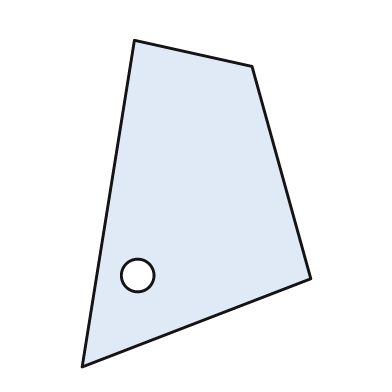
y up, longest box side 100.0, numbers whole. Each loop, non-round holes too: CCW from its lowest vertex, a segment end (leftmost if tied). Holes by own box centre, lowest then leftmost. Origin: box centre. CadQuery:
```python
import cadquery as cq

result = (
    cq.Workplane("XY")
    .moveTo(-35.0, -50.0)
    .lineTo(35.0, -23.0)
    .lineTo(17.0, 42.0)
    .lineTo(-19.0, 50.0)
    .close()
    .moveTo(-18.0, -22.0)
    .circle(5.0)
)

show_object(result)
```